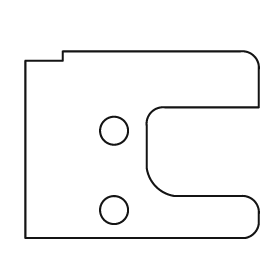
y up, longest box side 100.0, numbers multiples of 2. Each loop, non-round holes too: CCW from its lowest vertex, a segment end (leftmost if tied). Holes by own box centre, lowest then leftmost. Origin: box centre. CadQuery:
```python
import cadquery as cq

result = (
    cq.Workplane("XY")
    .moveTo(-50.0, -40.0)
    .lineTo(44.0, -40.0)
    .threePointArc((48.0, -38.0), (50.0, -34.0))
    .lineTo(50.0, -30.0)
    .threePointArc((48.0, -24.0), (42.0, -22.0))
    .lineTo(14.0, -22.0)
    .threePointArc((6.0, -18.0), (2.0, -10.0))
    .lineTo(2.0, 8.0)
    .threePointArc((4.0, 14.0), (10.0, 16.0))
    .lineTo(50.0, 16.0)
    .lineTo(50.0, 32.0)
    .threePointArc((48.0, 38.0), (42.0, 40.0))
    .lineTo(-34.0, 40.0)
    .lineTo(-34.0, 36.0)
    .lineTo(-50.0, 36.0)
    .close()
    .moveTo(-12.0, -28.0)
    .circle(6.0)
    .moveTo(-12.0, 6.0)
    .circle(6.0)
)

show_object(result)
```